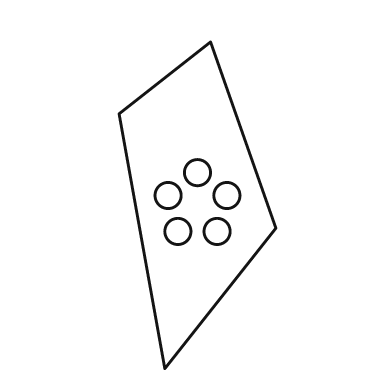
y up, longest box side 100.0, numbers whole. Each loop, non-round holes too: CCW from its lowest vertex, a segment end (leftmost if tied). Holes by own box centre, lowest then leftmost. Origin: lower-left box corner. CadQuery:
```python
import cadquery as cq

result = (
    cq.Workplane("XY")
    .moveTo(14.0, 0.0)
    .lineTo(48.0, 43.0)
    .lineTo(28.0, 100.0)
    .lineTo(0.0, 78.0)
    .close()
    .moveTo(18.0, 42.0)
    .circle(4.0)
    .moveTo(30.0, 42.0)
    .circle(4.0)
    .moveTo(15.0, 53.0)
    .circle(4.0)
    .moveTo(33.0, 53.0)
    .circle(4.0)
    .moveTo(24.0, 60.0)
    .circle(4.0)
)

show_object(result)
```